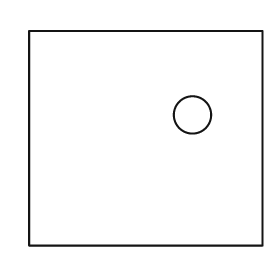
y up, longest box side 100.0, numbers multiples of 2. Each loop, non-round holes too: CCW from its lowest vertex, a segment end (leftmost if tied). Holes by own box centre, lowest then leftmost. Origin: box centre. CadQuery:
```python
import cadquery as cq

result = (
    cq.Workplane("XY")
    .moveTo(-50.0, -46.0)
    .lineTo(50.0, -46.0)
    .lineTo(50.0, 46.0)
    .lineTo(-50.0, 46.0)
    .close()
    .moveTo(20.0, 10.0)
    .circle(8.0)
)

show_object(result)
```